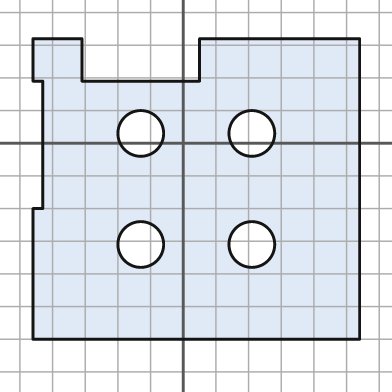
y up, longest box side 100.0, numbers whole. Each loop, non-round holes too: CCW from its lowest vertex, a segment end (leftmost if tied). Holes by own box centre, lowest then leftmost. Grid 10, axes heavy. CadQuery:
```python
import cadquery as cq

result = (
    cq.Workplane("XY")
    .moveTo(-46.0, -60.0)
    .lineTo(54.0, -60.0)
    .lineTo(54.0, 32.0)
    .lineTo(5.0, 32.0)
    .lineTo(5.0, 19.0)
    .lineTo(-31.0, 19.0)
    .lineTo(-31.0, 32.0)
    .lineTo(-46.0, 32.0)
    .lineTo(-46.0, 19.0)
    .lineTo(-43.0, 19.0)
    .lineTo(-43.0, -20.0)
    .lineTo(-46.0, -20.0)
    .close()
    .moveTo(-13.0, -31.0)
    .circle(7.0)
    .moveTo(21.0, -31.0)
    .circle(7.0)
    .moveTo(-13.0, 3.0)
    .circle(7.0)
    .moveTo(21.0, 3.0)
    .circle(7.0)
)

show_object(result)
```